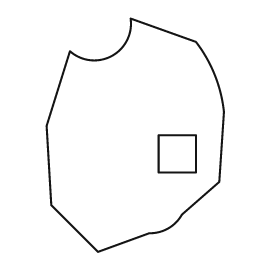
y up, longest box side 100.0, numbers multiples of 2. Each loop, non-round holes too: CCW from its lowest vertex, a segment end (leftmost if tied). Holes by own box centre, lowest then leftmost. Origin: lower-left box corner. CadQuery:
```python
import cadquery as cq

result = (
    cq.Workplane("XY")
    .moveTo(22.0, 0.0)
    .lineTo(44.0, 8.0)
    .threePointArc((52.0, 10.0), (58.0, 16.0))
    .lineTo(74.0, 30.0)
    .lineTo(76.0, 60.0)
    .threePointArc((72.0, 76.0), (64.0, 90.0))
    .lineTo(36.0, 100.0)
    .threePointArc((28.0, 84.0), (10.0, 86.0))
    .lineTo(0.0, 54.0)
    .lineTo(2.0, 20.0)
    .close()
    .moveTo(48.0, 34.0)
    .lineTo(64.0, 34.0)
    .lineTo(64.0, 50.0)
    .lineTo(48.0, 50.0)
    .close()
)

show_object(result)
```